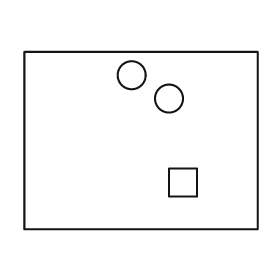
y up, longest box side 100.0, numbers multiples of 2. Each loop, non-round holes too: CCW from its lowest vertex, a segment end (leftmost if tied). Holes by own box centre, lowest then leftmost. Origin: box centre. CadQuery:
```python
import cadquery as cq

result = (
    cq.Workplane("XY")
    .moveTo(-50.0, -38.0)
    .lineTo(50.0, -38.0)
    .lineTo(50.0, 38.0)
    .lineTo(-50.0, 38.0)
    .close()
    .moveTo(12.0, -24.0)
    .lineTo(24.0, -24.0)
    .lineTo(24.0, -12.0)
    .lineTo(12.0, -12.0)
    .close()
    .moveTo(12.0, 18.0)
    .circle(6.0)
    .moveTo(-4.0, 28.0)
    .circle(6.0)
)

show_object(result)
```